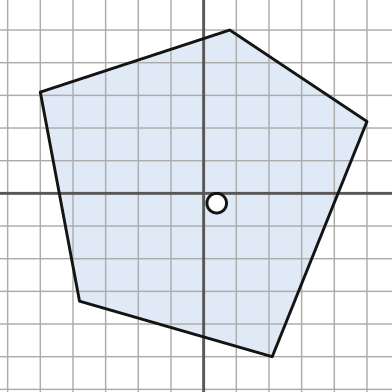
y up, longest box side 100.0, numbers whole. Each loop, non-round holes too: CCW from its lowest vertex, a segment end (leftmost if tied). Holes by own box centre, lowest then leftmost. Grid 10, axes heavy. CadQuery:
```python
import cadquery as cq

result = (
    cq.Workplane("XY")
    .moveTo(21.0, -50.0)
    .lineTo(50.0, 22.0)
    .lineTo(8.0, 50.0)
    .lineTo(-50.0, 31.0)
    .lineTo(-38.0, -33.0)
    .close()
    .moveTo(4.0, -3.0)
    .circle(3.0)
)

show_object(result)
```